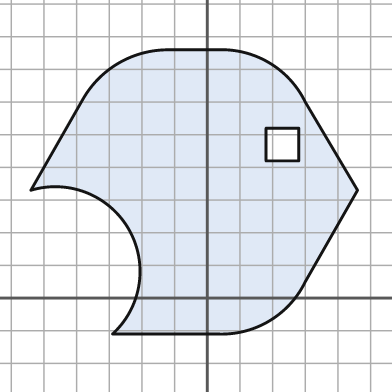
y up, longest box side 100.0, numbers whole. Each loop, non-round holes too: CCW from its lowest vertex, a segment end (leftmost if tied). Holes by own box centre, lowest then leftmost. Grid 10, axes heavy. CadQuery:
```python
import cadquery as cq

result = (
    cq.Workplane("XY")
    .moveTo(-29.0, -11.0)
    .lineTo(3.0, -11.0)
    .threePointArc((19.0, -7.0), (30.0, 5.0))
    .lineTo(46.0, 33.0)
    .lineTo(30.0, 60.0)
    .threePointArc((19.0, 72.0), (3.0, 76.0))
    .lineTo(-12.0, 76.0)
    .threePointArc((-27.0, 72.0), (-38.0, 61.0))
    .lineTo(-54.0, 33.0)
    .threePointArc((-24.0, 21.0), (-29.0, -11.0))
    .close()
    .moveTo(18.0, 42.0)
    .lineTo(28.0, 42.0)
    .lineTo(28.0, 52.0)
    .lineTo(18.0, 52.0)
    .close()
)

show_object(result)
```